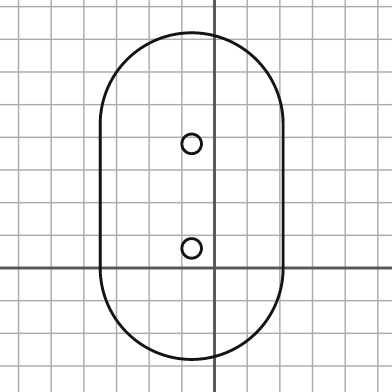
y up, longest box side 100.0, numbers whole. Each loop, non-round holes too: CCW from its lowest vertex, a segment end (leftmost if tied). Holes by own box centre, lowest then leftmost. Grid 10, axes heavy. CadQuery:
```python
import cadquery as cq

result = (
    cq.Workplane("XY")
    .moveTo(-35.0, 0.0)
    .threePointArc((-7.0, -28.0), (21.0, 0.0))
    .lineTo(21.0, 44.0)
    .threePointArc((-7.0, 72.0), (-35.0, 44.0))
    .close()
    .moveTo(-7.0, 6.0)
    .circle(3.0)
    .moveTo(-7.0, 38.0)
    .circle(3.0)
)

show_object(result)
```